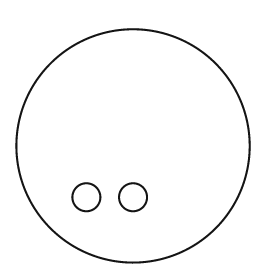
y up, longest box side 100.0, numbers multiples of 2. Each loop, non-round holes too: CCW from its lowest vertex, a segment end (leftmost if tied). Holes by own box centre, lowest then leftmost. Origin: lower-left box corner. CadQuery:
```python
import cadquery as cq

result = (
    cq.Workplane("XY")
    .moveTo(50.0, 50.0)
    .circle(50.0)
    .moveTo(30.0, 28.0)
    .circle(6.0)
    .moveTo(50.0, 28.0)
    .circle(6.0)
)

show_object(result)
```